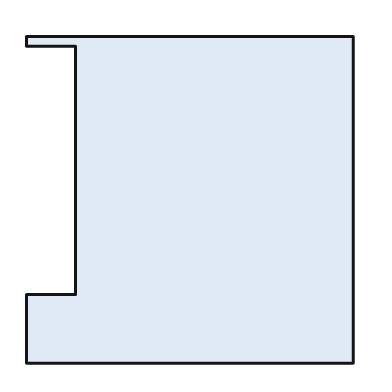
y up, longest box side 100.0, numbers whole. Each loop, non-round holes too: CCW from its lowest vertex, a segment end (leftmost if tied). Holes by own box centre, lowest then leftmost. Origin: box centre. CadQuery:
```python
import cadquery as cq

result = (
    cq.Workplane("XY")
    .moveTo(-50.0, -50.0)
    .lineTo(50.0, -50.0)
    .lineTo(50.0, 50.0)
    .lineTo(-50.0, 50.0)
    .lineTo(-50.0, 47.0)
    .lineTo(-35.0, 47.0)
    .lineTo(-35.0, -29.0)
    .lineTo(-50.0, -29.0)
    .close()
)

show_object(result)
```